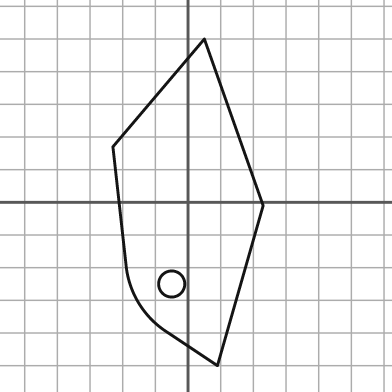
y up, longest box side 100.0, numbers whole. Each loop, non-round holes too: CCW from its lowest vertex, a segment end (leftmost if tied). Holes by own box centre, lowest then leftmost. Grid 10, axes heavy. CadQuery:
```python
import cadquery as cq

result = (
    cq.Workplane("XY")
    .moveTo(9.0, -50.0)
    .lineTo(23.0, -1.0)
    .lineTo(5.0, 50.0)
    .lineTo(-23.0, 17.0)
    .lineTo(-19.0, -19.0)
    .threePointArc((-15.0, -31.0), (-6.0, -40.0))
    .close()
    .moveTo(-5.0, -25.0)
    .circle(4.0)
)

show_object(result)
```